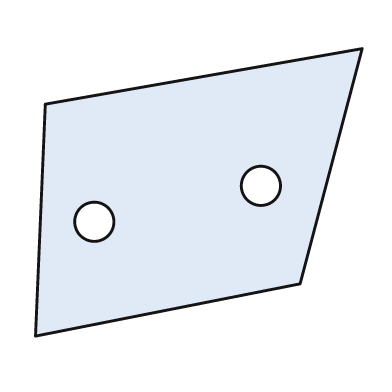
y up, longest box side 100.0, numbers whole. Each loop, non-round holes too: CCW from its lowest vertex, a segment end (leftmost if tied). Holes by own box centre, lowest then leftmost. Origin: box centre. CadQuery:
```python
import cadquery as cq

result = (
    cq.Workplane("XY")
    .moveTo(-50.0, -44.0)
    .lineTo(31.0, -28.0)
    .lineTo(50.0, 44.0)
    .lineTo(-47.0, 27.0)
    .close()
    .moveTo(-32.0, -9.0)
    .circle(6.0)
    .moveTo(19.0, 2.0)
    .circle(6.0)
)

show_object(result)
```